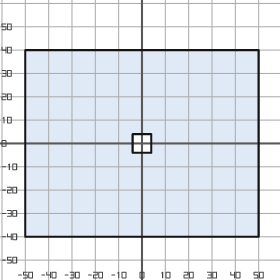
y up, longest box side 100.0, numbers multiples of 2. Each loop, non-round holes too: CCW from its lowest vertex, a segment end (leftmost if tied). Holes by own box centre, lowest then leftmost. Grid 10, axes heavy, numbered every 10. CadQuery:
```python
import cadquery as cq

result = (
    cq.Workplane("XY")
    .moveTo(-50.0, -40.0)
    .lineTo(50.0, -40.0)
    .lineTo(50.0, 40.0)
    .lineTo(-50.0, 40.0)
    .close()
    .moveTo(-4.0, -4.0)
    .lineTo(4.0, -4.0)
    .lineTo(4.0, 4.0)
    .lineTo(-4.0, 4.0)
    .close()
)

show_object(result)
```